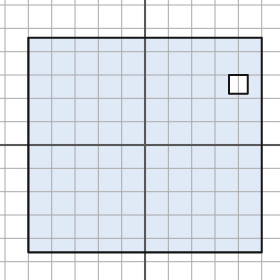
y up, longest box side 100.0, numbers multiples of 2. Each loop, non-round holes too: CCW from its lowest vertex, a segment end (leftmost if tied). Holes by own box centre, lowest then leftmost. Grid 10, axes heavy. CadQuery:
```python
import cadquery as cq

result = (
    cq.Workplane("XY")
    .moveTo(-50.0, -46.0)
    .lineTo(50.0, -46.0)
    .lineTo(50.0, 46.0)
    .lineTo(-50.0, 46.0)
    .close()
    .moveTo(36.0, 22.0)
    .lineTo(44.0, 22.0)
    .lineTo(44.0, 30.0)
    .lineTo(36.0, 30.0)
    .close()
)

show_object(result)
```